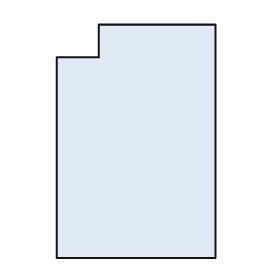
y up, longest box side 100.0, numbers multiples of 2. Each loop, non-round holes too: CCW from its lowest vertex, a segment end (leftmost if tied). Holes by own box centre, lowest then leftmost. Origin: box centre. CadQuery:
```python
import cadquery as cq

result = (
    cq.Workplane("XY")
    .moveTo(-34.0, -50.0)
    .lineTo(34.0, -50.0)
    .lineTo(34.0, 50.0)
    .lineTo(-16.0, 50.0)
    .lineTo(-16.0, 36.0)
    .lineTo(-34.0, 36.0)
    .close()
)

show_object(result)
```